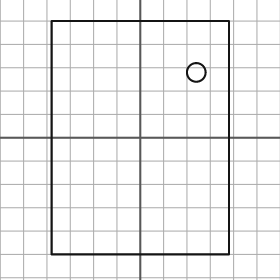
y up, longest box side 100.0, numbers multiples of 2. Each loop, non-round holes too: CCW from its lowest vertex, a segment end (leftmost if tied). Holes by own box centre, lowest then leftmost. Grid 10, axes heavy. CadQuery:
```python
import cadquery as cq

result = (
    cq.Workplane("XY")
    .moveTo(-38.0, -50.0)
    .lineTo(38.0, -50.0)
    .lineTo(38.0, 50.0)
    .lineTo(-38.0, 50.0)
    .close()
    .moveTo(24.0, 28.0)
    .circle(4.0)
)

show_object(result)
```